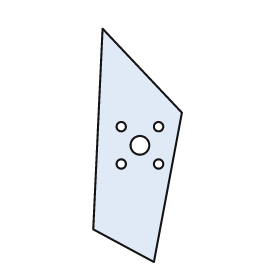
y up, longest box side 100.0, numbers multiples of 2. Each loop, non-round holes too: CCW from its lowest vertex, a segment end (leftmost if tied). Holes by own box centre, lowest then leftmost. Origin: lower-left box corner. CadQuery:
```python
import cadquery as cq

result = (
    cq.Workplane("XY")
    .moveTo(26.0, 0.0)
    .lineTo(38.0, 64.0)
    .lineTo(4.0, 100.0)
    .lineTo(0.0, 14.0)
    .close()
    .moveTo(12.0, 42.0)
    .circle(2.0)
    .moveTo(28.0, 42.0)
    .circle(2.0)
    .moveTo(20.0, 50.0)
    .circle(4.0)
    .moveTo(12.0, 58.0)
    .circle(2.0)
    .moveTo(28.0, 58.0)
    .circle(2.0)
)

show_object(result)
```